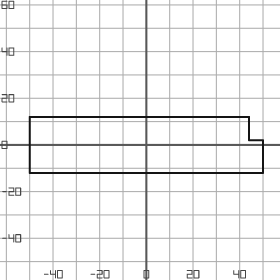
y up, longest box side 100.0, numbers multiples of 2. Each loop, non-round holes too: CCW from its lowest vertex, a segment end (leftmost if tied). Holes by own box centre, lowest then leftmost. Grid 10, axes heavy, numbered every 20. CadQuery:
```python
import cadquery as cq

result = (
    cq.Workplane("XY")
    .moveTo(-50.0, -12.0)
    .lineTo(50.0, -12.0)
    .lineTo(50.0, 2.0)
    .lineTo(44.0, 2.0)
    .lineTo(44.0, 12.0)
    .lineTo(-50.0, 12.0)
    .close()
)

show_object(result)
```